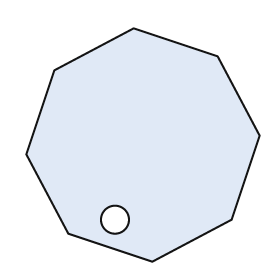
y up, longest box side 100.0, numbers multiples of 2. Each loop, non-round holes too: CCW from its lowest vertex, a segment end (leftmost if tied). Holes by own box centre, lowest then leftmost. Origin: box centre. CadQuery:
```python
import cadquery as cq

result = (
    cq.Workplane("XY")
    .moveTo(4.0, -50.0)
    .lineTo(38.0, -32.0)
    .lineTo(50.0, 4.0)
    .lineTo(32.0, 38.0)
    .lineTo(-4.0, 50.0)
    .lineTo(-38.0, 32.0)
    .lineTo(-50.0, -4.0)
    .lineTo(-32.0, -38.0)
    .close()
    .moveTo(-12.0, -32.0)
    .circle(6.0)
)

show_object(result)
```